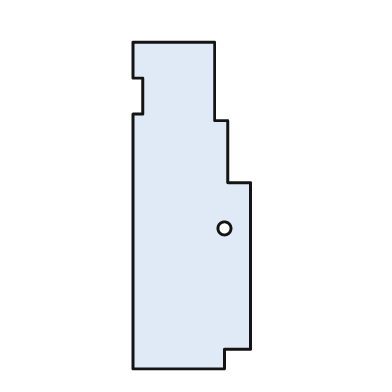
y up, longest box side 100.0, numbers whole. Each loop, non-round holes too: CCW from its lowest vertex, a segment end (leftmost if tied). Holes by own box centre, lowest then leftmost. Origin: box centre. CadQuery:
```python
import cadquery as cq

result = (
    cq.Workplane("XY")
    .moveTo(-18.0, -50.0)
    .lineTo(10.0, -50.0)
    .lineTo(10.0, -44.0)
    .lineTo(18.0, -44.0)
    .lineTo(18.0, 7.0)
    .lineTo(11.0, 7.0)
    .lineTo(11.0, 26.0)
    .lineTo(7.0, 26.0)
    .lineTo(7.0, 50.0)
    .lineTo(-18.0, 50.0)
    .lineTo(-18.0, 39.0)
    .lineTo(-15.0, 39.0)
    .lineTo(-15.0, 28.0)
    .lineTo(-18.0, 28.0)
    .close()
    .moveTo(10.0, -7.0)
    .circle(2.0)
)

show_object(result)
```